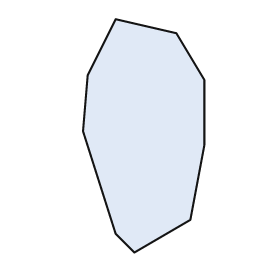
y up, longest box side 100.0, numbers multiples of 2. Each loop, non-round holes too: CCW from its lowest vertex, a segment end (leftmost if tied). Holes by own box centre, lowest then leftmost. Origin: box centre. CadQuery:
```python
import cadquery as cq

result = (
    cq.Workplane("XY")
    .moveTo(-4.0, -50.0)
    .lineTo(20.0, -36.0)
    .lineTo(26.0, -4.0)
    .lineTo(26.0, 24.0)
    .lineTo(14.0, 44.0)
    .lineTo(-12.0, 50.0)
    .lineTo(-24.0, 26.0)
    .lineTo(-26.0, 2.0)
    .lineTo(-12.0, -42.0)
    .close()
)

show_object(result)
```